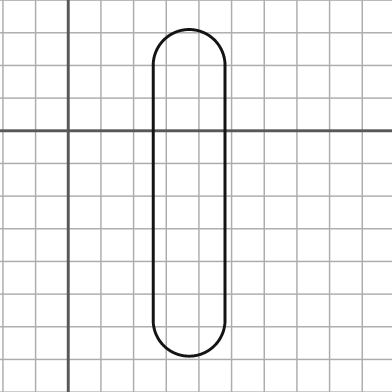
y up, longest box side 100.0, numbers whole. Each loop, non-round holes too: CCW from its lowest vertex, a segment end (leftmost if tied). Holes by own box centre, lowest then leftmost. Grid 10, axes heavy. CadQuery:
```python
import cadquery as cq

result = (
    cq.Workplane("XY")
    .moveTo(26.0, -58.0)
    .threePointArc((37.0, -69.0), (48.0, -58.0))
    .lineTo(48.0, 20.0)
    .threePointArc((37.0, 31.0), (26.0, 20.0))
    .close()
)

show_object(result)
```